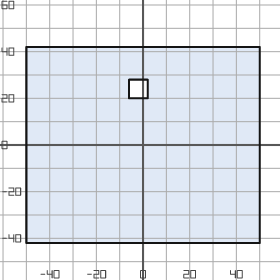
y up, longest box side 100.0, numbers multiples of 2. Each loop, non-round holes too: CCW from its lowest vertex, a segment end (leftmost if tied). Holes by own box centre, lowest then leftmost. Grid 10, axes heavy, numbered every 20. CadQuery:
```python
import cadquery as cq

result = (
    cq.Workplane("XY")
    .moveTo(-50.0, -42.0)
    .lineTo(50.0, -42.0)
    .lineTo(50.0, 42.0)
    .lineTo(-50.0, 42.0)
    .close()
    .moveTo(-6.0, 20.0)
    .lineTo(2.0, 20.0)
    .lineTo(2.0, 28.0)
    .lineTo(-6.0, 28.0)
    .close()
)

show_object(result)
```